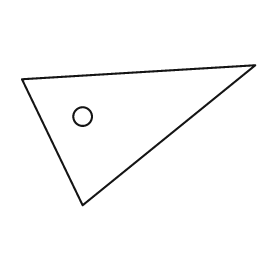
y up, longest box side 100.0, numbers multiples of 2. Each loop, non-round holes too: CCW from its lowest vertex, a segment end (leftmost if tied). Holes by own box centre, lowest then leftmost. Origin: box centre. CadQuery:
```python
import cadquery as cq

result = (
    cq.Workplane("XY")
    .moveTo(-24.0, -30.0)
    .lineTo(50.0, 30.0)
    .lineTo(-50.0, 24.0)
    .close()
    .moveTo(-24.0, 8.0)
    .circle(4.0)
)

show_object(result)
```